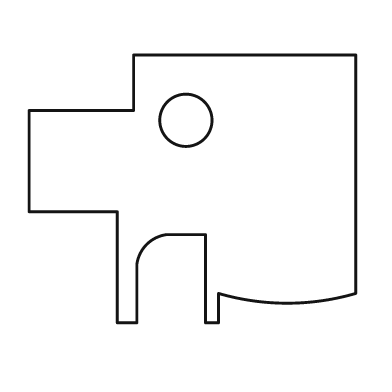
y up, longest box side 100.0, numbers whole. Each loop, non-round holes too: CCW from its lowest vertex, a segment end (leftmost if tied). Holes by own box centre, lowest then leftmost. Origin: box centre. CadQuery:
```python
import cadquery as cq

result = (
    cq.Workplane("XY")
    .moveTo(-23.0, -41.0)
    .lineTo(-17.0, -41.0)
    .lineTo(-17.0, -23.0)
    .threePointArc((-14.0, -17.0), (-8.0, -14.0))
    .lineTo(4.0, -14.0)
    .lineTo(4.0, -41.0)
    .lineTo(8.0, -41.0)
    .lineTo(8.0, -32.0)
    .threePointArc((29.0, -35.0), (50.0, -32.0))
    .lineTo(50.0, 41.0)
    .lineTo(-18.0, 41.0)
    .lineTo(-18.0, 24.0)
    .lineTo(-50.0, 24.0)
    .lineTo(-50.0, -7.0)
    .lineTo(-23.0, -7.0)
    .close()
    .moveTo(-2.0, 21.0)
    .circle(8.0)
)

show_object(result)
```